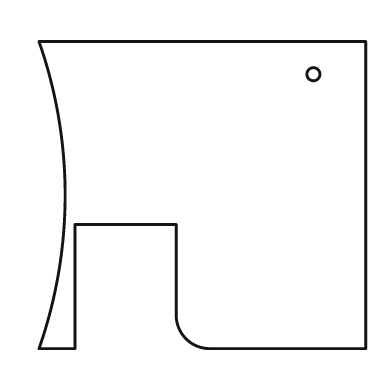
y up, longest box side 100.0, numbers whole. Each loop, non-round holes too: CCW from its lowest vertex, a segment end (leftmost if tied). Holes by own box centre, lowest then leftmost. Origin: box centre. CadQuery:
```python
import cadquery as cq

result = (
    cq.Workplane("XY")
    .moveTo(-50.0, -47.0)
    .lineTo(-39.0, -47.0)
    .lineTo(-39.0, -9.0)
    .lineTo(-8.0, -9.0)
    .lineTo(-8.0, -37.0)
    .threePointArc((-5.0, -44.0), (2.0, -47.0))
    .lineTo(50.0, -47.0)
    .lineTo(50.0, 47.0)
    .lineTo(-50.0, 47.0)
    .threePointArc((-42.0, 0.0), (-50.0, -47.0))
    .close()
    .moveTo(34.0, 37.0)
    .circle(2.0)
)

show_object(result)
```